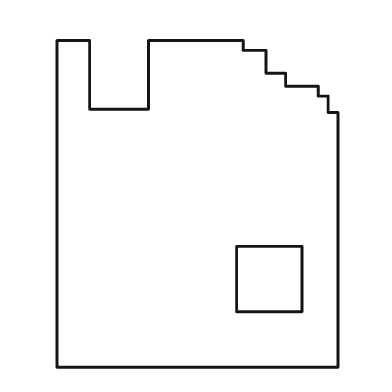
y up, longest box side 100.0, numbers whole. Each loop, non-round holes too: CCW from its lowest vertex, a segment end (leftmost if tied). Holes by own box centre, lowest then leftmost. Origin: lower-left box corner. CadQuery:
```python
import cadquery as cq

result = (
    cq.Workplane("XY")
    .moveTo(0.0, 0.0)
    .lineTo(86.0, 0.0)
    .lineTo(86.0, 78.0)
    .lineTo(83.0, 78.0)
    .lineTo(83.0, 83.0)
    .lineTo(80.0, 83.0)
    .lineTo(80.0, 86.0)
    .lineTo(70.0, 86.0)
    .lineTo(70.0, 90.0)
    .lineTo(64.0, 90.0)
    .lineTo(64.0, 97.0)
    .lineTo(57.0, 97.0)
    .lineTo(57.0, 100.0)
    .lineTo(28.0, 100.0)
    .lineTo(28.0, 79.0)
    .lineTo(10.0, 79.0)
    .lineTo(10.0, 100.0)
    .lineTo(0.0, 100.0)
    .close()
    .moveTo(55.0, 17.0)
    .lineTo(75.0, 17.0)
    .lineTo(75.0, 37.0)
    .lineTo(55.0, 37.0)
    .close()
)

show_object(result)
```